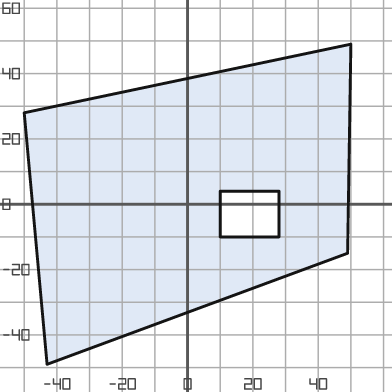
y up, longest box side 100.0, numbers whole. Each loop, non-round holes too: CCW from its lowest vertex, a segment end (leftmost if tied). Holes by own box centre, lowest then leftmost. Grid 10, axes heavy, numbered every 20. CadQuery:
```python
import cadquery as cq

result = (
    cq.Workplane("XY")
    .moveTo(-43.0, -49.0)
    .lineTo(49.0, -15.0)
    .lineTo(50.0, 49.0)
    .lineTo(-50.0, 28.0)
    .close()
    .moveTo(10.0, -10.0)
    .lineTo(28.0, -10.0)
    .lineTo(28.0, 4.0)
    .lineTo(10.0, 4.0)
    .close()
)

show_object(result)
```